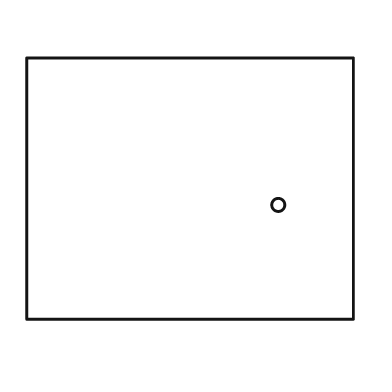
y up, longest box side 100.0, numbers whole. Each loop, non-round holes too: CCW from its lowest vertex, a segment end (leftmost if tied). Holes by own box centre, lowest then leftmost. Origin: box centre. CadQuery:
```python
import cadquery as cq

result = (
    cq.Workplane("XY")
    .moveTo(-50.0, -40.0)
    .lineTo(50.0, -40.0)
    .lineTo(50.0, 40.0)
    .lineTo(-50.0, 40.0)
    .close()
    .moveTo(27.0, -5.0)
    .circle(2.0)
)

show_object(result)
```